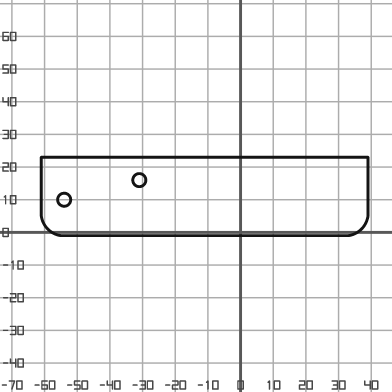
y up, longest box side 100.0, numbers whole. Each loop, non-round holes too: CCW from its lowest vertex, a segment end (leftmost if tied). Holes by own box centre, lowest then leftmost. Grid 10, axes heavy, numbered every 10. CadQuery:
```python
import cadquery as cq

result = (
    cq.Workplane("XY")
    .moveTo(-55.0, -1.0)
    .lineTo(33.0, -1.0)
    .threePointArc((37.0, 1.0), (39.0, 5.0))
    .lineTo(39.0, 23.0)
    .lineTo(-61.0, 23.0)
    .lineTo(-61.0, 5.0)
    .threePointArc((-59.0, 1.0), (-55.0, -1.0))
    .close()
    .moveTo(-54.0, 10.0)
    .circle(2.0)
    .moveTo(-31.0, 16.0)
    .circle(2.0)
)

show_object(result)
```